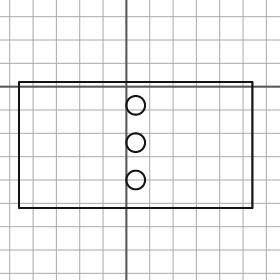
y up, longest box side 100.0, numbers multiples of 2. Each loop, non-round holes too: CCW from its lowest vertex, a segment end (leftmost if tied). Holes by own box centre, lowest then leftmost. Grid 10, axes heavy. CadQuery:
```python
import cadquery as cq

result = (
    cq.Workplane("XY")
    .moveTo(-46.0, -52.0)
    .lineTo(54.0, -52.0)
    .lineTo(54.0, 2.0)
    .lineTo(-46.0, 2.0)
    .close()
    .moveTo(4.0, -40.0)
    .circle(4.0)
    .moveTo(4.0, -24.0)
    .circle(4.0)
    .moveTo(4.0, -8.0)
    .circle(4.0)
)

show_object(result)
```